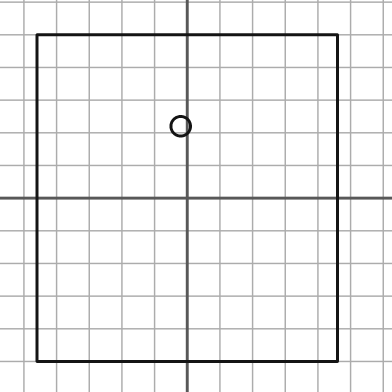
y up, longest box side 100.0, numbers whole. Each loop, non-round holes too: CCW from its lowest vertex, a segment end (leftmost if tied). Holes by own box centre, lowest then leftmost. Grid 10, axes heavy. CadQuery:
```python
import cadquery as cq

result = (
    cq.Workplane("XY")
    .moveTo(-46.0, -50.0)
    .lineTo(46.0, -50.0)
    .lineTo(46.0, 50.0)
    .lineTo(-46.0, 50.0)
    .close()
    .moveTo(-2.0, 22.0)
    .circle(3.0)
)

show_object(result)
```